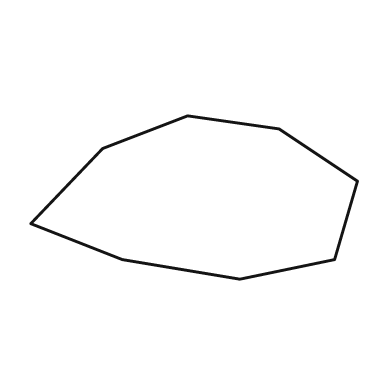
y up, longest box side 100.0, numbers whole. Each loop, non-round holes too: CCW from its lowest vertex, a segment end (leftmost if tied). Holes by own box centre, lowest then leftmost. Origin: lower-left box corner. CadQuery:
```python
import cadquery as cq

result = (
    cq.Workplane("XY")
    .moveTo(64.0, 0.0)
    .lineTo(93.0, 6.0)
    .lineTo(100.0, 30.0)
    .lineTo(76.0, 46.0)
    .lineTo(48.0, 50.0)
    .lineTo(22.0, 40.0)
    .lineTo(0.0, 17.0)
    .lineTo(28.0, 6.0)
    .close()
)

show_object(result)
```